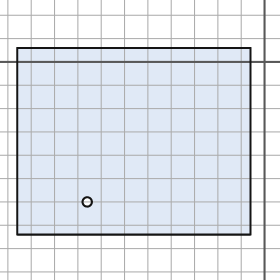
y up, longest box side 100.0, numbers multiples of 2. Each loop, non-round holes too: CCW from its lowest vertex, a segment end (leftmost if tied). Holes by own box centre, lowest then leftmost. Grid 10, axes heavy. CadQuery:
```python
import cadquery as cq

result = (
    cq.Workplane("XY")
    .moveTo(-106.0, -74.0)
    .lineTo(-6.0, -74.0)
    .lineTo(-6.0, 6.0)
    .lineTo(-106.0, 6.0)
    .close()
    .moveTo(-76.0, -60.0)
    .circle(2.0)
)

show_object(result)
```